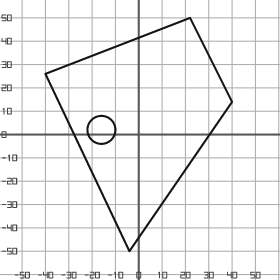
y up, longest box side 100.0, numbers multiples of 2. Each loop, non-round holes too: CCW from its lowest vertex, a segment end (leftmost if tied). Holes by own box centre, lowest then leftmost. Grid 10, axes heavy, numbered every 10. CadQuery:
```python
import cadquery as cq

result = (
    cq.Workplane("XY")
    .moveTo(-4.0, -50.0)
    .lineTo(40.0, 14.0)
    .lineTo(22.0, 50.0)
    .lineTo(-40.0, 26.0)
    .close()
    .moveTo(-16.0, 2.0)
    .circle(6.0)
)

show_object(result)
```